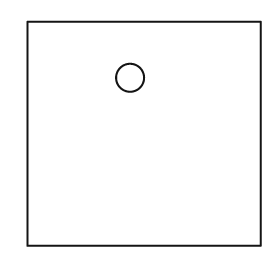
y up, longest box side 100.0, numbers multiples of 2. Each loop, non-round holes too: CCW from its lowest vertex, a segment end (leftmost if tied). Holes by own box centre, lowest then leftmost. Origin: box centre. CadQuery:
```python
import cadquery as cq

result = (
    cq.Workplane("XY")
    .moveTo(-50.0, -48.0)
    .lineTo(50.0, -48.0)
    .lineTo(50.0, 48.0)
    .lineTo(-50.0, 48.0)
    .close()
    .moveTo(-6.0, 24.0)
    .circle(6.0)
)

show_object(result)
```